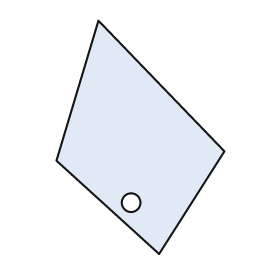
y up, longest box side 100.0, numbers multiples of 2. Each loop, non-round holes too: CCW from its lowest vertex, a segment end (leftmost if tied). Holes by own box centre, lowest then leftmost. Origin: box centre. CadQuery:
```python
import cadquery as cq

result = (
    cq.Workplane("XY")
    .moveTo(8.0, -50.0)
    .lineTo(36.0, -6.0)
    .lineTo(-18.0, 50.0)
    .lineTo(-36.0, -10.0)
    .close()
    .moveTo(-4.0, -28.0)
    .circle(4.0)
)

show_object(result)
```